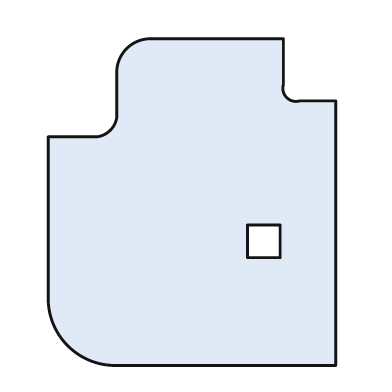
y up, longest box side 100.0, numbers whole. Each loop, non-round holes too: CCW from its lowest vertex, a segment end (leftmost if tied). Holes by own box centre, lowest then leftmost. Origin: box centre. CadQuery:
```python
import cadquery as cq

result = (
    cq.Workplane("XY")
    .moveTo(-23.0, -50.0)
    .lineTo(44.0, -50.0)
    .lineTo(44.0, 31.0)
    .lineTo(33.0, 31.0)
    .threePointArc((29.0, 32.0), (28.0, 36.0))
    .lineTo(28.0, 50.0)
    .lineTo(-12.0, 50.0)
    .threePointArc((-20.0, 47.0), (-23.0, 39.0))
    .lineTo(-23.0, 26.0)
    .threePointArc((-25.0, 22.0), (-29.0, 20.0))
    .lineTo(-44.0, 20.0)
    .lineTo(-44.0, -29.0)
    .threePointArc((-38.0, -44.0), (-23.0, -50.0))
    .close()
    .moveTo(17.0, -17.0)
    .lineTo(27.0, -17.0)
    .lineTo(27.0, -7.0)
    .lineTo(17.0, -7.0)
    .close()
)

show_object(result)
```